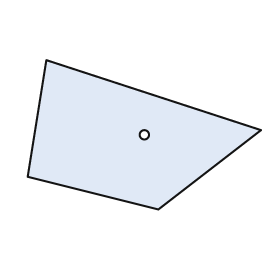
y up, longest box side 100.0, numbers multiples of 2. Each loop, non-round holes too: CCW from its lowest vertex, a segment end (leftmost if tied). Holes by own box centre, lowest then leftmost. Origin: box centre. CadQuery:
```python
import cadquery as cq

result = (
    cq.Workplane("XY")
    .moveTo(6.0, -32.0)
    .lineTo(50.0, 2.0)
    .lineTo(-42.0, 32.0)
    .lineTo(-50.0, -18.0)
    .close()
    .moveTo(0.0, 0.0)
    .circle(2.0)
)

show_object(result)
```